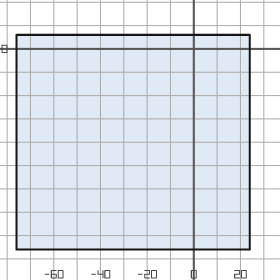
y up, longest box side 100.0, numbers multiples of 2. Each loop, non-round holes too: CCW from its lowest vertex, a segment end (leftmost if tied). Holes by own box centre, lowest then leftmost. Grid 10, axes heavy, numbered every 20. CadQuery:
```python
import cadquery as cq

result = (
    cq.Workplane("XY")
    .moveTo(-76.0, -86.0)
    .lineTo(24.0, -86.0)
    .lineTo(24.0, 6.0)
    .lineTo(-76.0, 6.0)
    .close()
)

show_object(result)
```